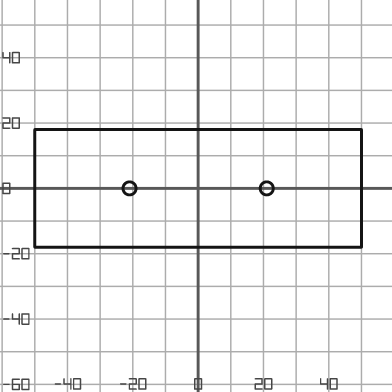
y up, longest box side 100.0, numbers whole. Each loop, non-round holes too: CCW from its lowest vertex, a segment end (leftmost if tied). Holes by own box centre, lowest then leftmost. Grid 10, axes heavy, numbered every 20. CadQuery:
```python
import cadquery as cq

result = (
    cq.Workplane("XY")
    .moveTo(-50.0, -18.0)
    .lineTo(50.0, -18.0)
    .lineTo(50.0, 18.0)
    .lineTo(-50.0, 18.0)
    .close()
    .moveTo(-21.0, 0.0)
    .circle(2.0)
    .moveTo(21.0, 0.0)
    .circle(2.0)
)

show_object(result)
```